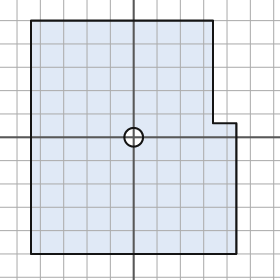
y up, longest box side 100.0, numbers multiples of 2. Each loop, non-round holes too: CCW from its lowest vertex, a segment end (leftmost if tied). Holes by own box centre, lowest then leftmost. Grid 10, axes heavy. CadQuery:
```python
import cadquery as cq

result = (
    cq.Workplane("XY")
    .moveTo(-44.0, -50.0)
    .lineTo(44.0, -50.0)
    .lineTo(44.0, 6.0)
    .lineTo(34.0, 6.0)
    .lineTo(34.0, 50.0)
    .lineTo(-44.0, 50.0)
    .close()
    .moveTo(0.0, 0.0)
    .circle(4.0)
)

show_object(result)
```